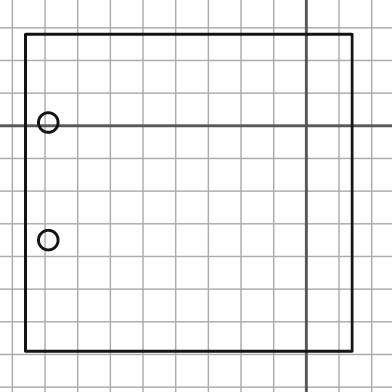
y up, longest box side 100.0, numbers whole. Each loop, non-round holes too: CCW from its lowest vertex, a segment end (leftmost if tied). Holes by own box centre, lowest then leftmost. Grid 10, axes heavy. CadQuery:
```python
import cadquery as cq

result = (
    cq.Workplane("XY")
    .moveTo(-86.0, -69.0)
    .lineTo(14.0, -69.0)
    .lineTo(14.0, 28.0)
    .lineTo(-86.0, 28.0)
    .close()
    .moveTo(-79.0, -35.0)
    .circle(3.0)
    .moveTo(-79.0, 1.0)
    .circle(3.0)
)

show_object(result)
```